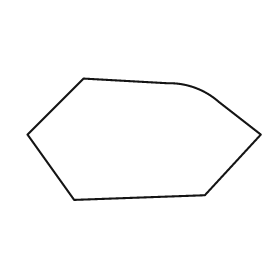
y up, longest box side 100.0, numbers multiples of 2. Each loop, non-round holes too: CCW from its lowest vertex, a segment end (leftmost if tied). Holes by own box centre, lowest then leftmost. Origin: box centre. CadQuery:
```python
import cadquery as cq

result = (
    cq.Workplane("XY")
    .moveTo(-30.0, -26.0)
    .lineTo(26.0, -24.0)
    .lineTo(50.0, 2.0)
    .lineTo(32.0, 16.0)
    .threePointArc((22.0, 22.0), (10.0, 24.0))
    .lineTo(-26.0, 26.0)
    .lineTo(-50.0, 2.0)
    .close()
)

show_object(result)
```